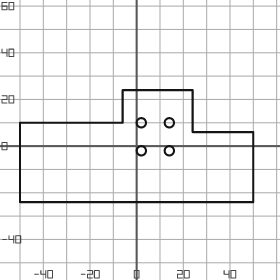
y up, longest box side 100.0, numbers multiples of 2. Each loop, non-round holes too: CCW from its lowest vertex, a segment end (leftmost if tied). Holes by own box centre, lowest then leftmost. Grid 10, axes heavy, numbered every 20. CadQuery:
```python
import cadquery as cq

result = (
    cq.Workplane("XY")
    .moveTo(-50.0, -24.0)
    .lineTo(50.0, -24.0)
    .lineTo(50.0, 6.0)
    .lineTo(24.0, 6.0)
    .lineTo(24.0, 24.0)
    .lineTo(-6.0, 24.0)
    .lineTo(-6.0, 10.0)
    .lineTo(-50.0, 10.0)
    .close()
    .moveTo(2.0, -2.0)
    .circle(2.0)
    .moveTo(14.0, -2.0)
    .circle(2.0)
    .moveTo(2.0, 10.0)
    .circle(2.0)
    .moveTo(14.0, 10.0)
    .circle(2.0)
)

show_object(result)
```